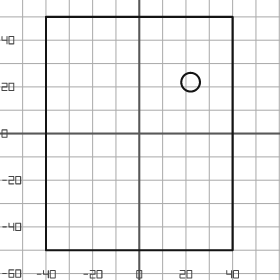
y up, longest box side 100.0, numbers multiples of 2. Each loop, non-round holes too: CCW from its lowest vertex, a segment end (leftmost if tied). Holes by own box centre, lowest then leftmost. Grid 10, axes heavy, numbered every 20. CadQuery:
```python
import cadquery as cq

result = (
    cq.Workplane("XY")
    .moveTo(-40.0, -50.0)
    .lineTo(40.0, -50.0)
    .lineTo(40.0, 50.0)
    .lineTo(-40.0, 50.0)
    .close()
    .moveTo(22.0, 22.0)
    .circle(4.0)
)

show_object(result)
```